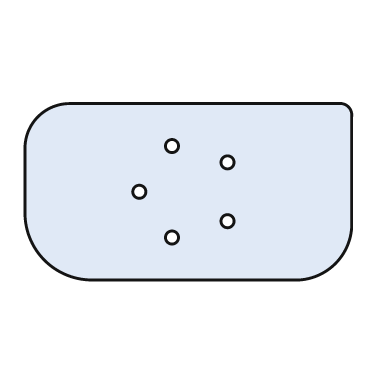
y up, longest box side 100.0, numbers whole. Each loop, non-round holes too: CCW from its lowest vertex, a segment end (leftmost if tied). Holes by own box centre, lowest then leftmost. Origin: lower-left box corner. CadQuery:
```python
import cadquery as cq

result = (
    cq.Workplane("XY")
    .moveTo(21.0, 0.0)
    .lineTo(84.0, 0.0)
    .threePointArc((95.0, 5.0), (100.0, 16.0))
    .lineTo(100.0, 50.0)
    .threePointArc((99.0, 53.0), (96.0, 54.0))
    .lineTo(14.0, 54.0)
    .threePointArc((4.0, 50.0), (0.0, 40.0))
    .lineTo(0.0, 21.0)
    .threePointArc((6.0, 6.0), (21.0, 0.0))
    .close()
    .moveTo(45.0, 13.0)
    .circle(2.0)
    .moveTo(62.0, 18.0)
    .circle(2.0)
    .moveTo(35.0, 27.0)
    .circle(2.0)
    .moveTo(62.0, 36.0)
    .circle(2.0)
    .moveTo(45.0, 41.0)
    .circle(2.0)
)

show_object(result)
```